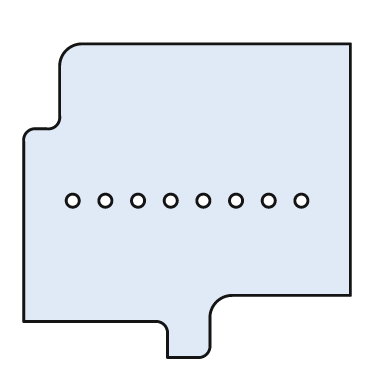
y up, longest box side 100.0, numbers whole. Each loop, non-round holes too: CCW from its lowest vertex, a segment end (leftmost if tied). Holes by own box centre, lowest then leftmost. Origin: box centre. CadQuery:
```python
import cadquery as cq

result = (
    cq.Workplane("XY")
    .moveTo(-6.0, -48.0)
    .lineTo(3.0, -48.0)
    .threePointArc((6.0, -47.0), (7.0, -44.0))
    .lineTo(7.0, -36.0)
    .threePointArc((9.0, -31.0), (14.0, -29.0))
    .lineTo(50.0, -29.0)
    .lineTo(50.0, 48.0)
    .lineTo(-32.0, 48.0)
    .threePointArc((-37.0, 46.0), (-39.0, 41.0))
    .lineTo(-39.0, 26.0)
    .threePointArc((-40.0, 23.0), (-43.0, 22.0))
    .lineTo(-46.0, 22.0)
    .threePointArc((-49.0, 21.0), (-50.0, 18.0))
    .lineTo(-50.0, -37.0)
    .lineTo(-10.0, -37.0)
    .threePointArc((-7.0, -38.0), (-6.0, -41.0))
    .close()
    .moveTo(-35.0, 0.0)
    .circle(2.0)
    .moveTo(-25.0, 0.0)
    .circle(2.0)
    .moveTo(-15.0, 0.0)
    .circle(2.0)
    .moveTo(-5.0, 0.0)
    .circle(2.0)
    .moveTo(5.0, 0.0)
    .circle(2.0)
    .moveTo(15.0, 0.0)
    .circle(2.0)
    .moveTo(25.0, 0.0)
    .circle(2.0)
    .moveTo(35.0, 0.0)
    .circle(2.0)
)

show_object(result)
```